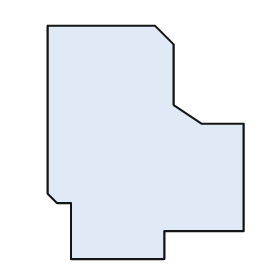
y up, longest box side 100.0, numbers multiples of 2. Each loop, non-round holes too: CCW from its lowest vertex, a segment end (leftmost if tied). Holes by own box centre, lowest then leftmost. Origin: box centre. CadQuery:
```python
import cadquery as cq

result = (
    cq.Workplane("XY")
    .moveTo(-32.0, -50.0)
    .lineTo(8.0, -50.0)
    .lineTo(8.0, -38.0)
    .lineTo(42.0, -38.0)
    .lineTo(42.0, 8.0)
    .lineTo(24.0, 8.0)
    .lineTo(12.0, 16.0)
    .lineTo(12.0, 42.0)
    .lineTo(4.0, 50.0)
    .lineTo(-42.0, 50.0)
    .lineTo(-42.0, -22.0)
    .lineTo(-38.0, -26.0)
    .lineTo(-32.0, -26.0)
    .close()
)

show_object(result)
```